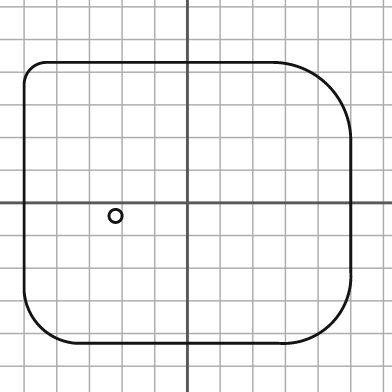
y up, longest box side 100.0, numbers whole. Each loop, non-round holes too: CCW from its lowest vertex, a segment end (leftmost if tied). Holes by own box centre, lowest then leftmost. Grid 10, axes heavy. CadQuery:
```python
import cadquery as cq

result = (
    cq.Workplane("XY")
    .moveTo(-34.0, -43.0)
    .lineTo(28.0, -43.0)
    .threePointArc((44.0, -37.0), (50.0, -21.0))
    .lineTo(50.0, 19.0)
    .threePointArc((43.0, 36.0), (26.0, 43.0))
    .lineTo(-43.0, 43.0)
    .threePointArc((-48.0, 41.0), (-50.0, 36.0))
    .lineTo(-50.0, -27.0)
    .threePointArc((-45.0, -38.0), (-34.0, -43.0))
    .close()
    .moveTo(-22.0, -4.0)
    .circle(2.0)
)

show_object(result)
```